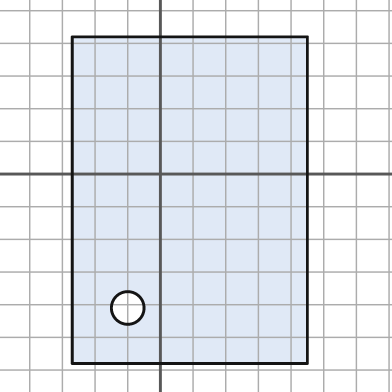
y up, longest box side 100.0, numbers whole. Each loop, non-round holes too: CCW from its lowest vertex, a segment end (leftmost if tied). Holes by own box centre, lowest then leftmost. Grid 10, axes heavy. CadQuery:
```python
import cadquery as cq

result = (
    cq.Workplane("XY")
    .moveTo(-27.0, -58.0)
    .lineTo(45.0, -58.0)
    .lineTo(45.0, 42.0)
    .lineTo(-27.0, 42.0)
    .close()
    .moveTo(-10.0, -41.0)
    .circle(5.0)
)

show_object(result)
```